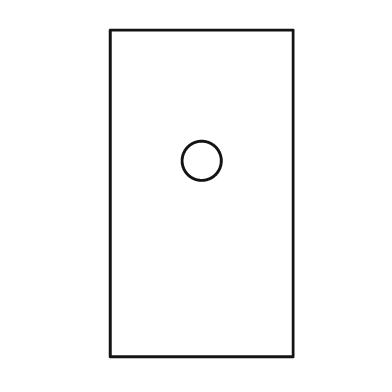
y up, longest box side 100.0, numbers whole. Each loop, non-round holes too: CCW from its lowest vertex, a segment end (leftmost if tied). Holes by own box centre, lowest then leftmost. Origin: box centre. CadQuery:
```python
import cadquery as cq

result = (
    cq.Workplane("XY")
    .moveTo(-28.0, -50.0)
    .lineTo(28.0, -50.0)
    .lineTo(28.0, 50.0)
    .lineTo(-28.0, 50.0)
    .close()
    .moveTo(0.0, 10.0)
    .circle(6.0)
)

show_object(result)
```